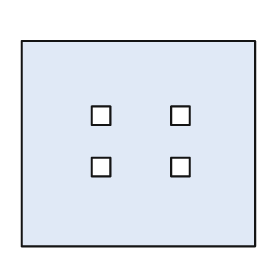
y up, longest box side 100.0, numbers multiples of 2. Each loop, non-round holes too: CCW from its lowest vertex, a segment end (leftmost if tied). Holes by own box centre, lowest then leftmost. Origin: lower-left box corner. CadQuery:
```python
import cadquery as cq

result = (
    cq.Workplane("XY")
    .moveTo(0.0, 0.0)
    .lineTo(100.0, 0.0)
    .lineTo(100.0, 88.0)
    .lineTo(0.0, 88.0)
    .close()
    .moveTo(30.0, 30.0)
    .lineTo(38.0, 30.0)
    .lineTo(38.0, 38.0)
    .lineTo(30.0, 38.0)
    .close()
    .moveTo(64.0, 30.0)
    .lineTo(72.0, 30.0)
    .lineTo(72.0, 38.0)
    .lineTo(64.0, 38.0)
    .close()
    .moveTo(30.0, 52.0)
    .lineTo(38.0, 52.0)
    .lineTo(38.0, 60.0)
    .lineTo(30.0, 60.0)
    .close()
    .moveTo(64.0, 52.0)
    .lineTo(72.0, 52.0)
    .lineTo(72.0, 60.0)
    .lineTo(64.0, 60.0)
    .close()
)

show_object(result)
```